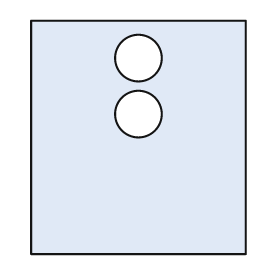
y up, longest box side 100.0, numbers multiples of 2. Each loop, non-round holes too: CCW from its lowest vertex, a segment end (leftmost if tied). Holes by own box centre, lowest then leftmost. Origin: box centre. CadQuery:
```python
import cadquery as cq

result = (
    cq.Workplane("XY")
    .moveTo(-46.0, -50.0)
    .lineTo(46.0, -50.0)
    .lineTo(46.0, 50.0)
    .lineTo(-46.0, 50.0)
    .close()
    .moveTo(0.0, 10.0)
    .circle(10.0)
    .moveTo(0.0, 34.0)
    .circle(10.0)
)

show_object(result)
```